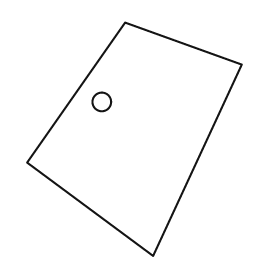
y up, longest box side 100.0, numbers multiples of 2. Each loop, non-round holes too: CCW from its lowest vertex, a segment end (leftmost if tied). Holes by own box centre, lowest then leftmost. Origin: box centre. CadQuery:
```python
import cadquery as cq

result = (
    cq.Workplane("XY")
    .moveTo(8.0, -50.0)
    .lineTo(46.0, 32.0)
    .lineTo(-4.0, 50.0)
    .lineTo(-46.0, -10.0)
    .close()
    .moveTo(-14.0, 16.0)
    .circle(4.0)
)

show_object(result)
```